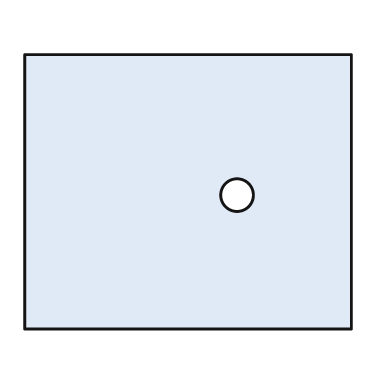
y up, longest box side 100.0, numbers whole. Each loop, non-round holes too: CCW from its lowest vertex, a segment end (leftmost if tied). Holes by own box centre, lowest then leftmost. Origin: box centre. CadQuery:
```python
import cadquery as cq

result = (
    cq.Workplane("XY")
    .moveTo(-50.0, -42.0)
    .lineTo(50.0, -42.0)
    .lineTo(50.0, 42.0)
    .lineTo(-50.0, 42.0)
    .close()
    .moveTo(15.0, -1.0)
    .circle(5.0)
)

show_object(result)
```